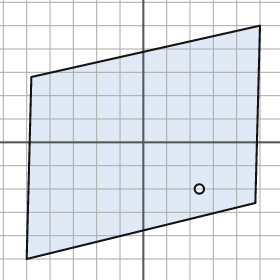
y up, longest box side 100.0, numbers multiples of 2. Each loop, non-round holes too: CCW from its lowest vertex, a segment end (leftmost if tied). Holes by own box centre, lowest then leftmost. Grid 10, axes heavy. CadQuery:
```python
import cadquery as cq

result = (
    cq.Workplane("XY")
    .moveTo(-50.0, -50.0)
    .lineTo(48.0, -26.0)
    .lineTo(50.0, 50.0)
    .lineTo(-48.0, 28.0)
    .close()
    .moveTo(24.0, -20.0)
    .circle(2.0)
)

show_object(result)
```